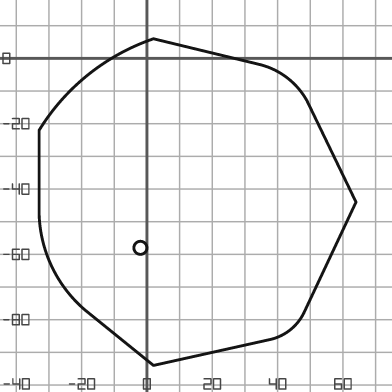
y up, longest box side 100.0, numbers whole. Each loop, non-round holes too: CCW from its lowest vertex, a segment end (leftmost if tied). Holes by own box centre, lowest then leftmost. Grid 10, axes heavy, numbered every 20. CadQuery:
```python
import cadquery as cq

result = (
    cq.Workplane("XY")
    .moveTo(2.0, -94.0)
    .lineTo(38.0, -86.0)
    .threePointArc((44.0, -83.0), (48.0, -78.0))
    .lineTo(64.0, -44.0)
    .lineTo(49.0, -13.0)
    .threePointArc((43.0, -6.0), (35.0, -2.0))
    .lineTo(2.0, 6.0)
    .threePointArc((-18.0, -5.0), (-33.0, -22.0))
    .lineTo(-33.0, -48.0)
    .threePointArc((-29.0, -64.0), (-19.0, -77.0))
    .close()
    .moveTo(-2.0, -58.0)
    .circle(2.0)
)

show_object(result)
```